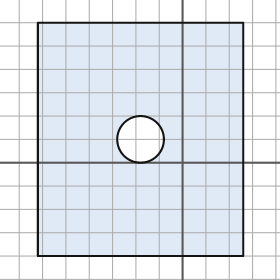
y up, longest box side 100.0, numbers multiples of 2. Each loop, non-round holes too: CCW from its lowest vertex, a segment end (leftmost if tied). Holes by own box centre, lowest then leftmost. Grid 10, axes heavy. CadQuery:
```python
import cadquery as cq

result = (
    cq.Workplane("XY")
    .moveTo(-62.0, -40.0)
    .lineTo(26.0, -40.0)
    .lineTo(26.0, 60.0)
    .lineTo(-62.0, 60.0)
    .close()
    .moveTo(-18.0, 10.0)
    .circle(10.0)
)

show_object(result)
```